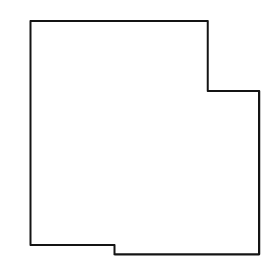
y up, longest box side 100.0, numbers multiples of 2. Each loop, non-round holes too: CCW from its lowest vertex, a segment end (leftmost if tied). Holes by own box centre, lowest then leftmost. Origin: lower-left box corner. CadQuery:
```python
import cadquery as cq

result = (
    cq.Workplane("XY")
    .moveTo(36.0, 0.0)
    .lineTo(98.0, 0.0)
    .lineTo(98.0, 70.0)
    .lineTo(76.0, 70.0)
    .lineTo(76.0, 100.0)
    .lineTo(0.0, 100.0)
    .lineTo(0.0, 4.0)
    .lineTo(36.0, 4.0)
    .close()
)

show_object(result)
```